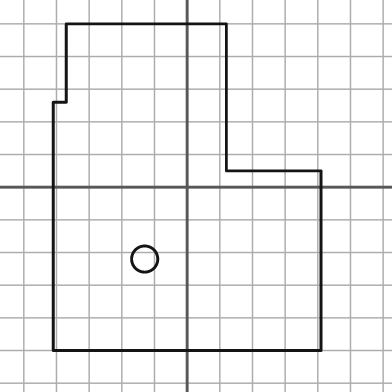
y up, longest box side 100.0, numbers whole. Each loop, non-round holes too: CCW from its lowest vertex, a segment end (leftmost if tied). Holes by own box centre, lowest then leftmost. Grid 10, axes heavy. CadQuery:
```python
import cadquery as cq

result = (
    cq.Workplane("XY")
    .moveTo(-41.0, -50.0)
    .lineTo(41.0, -50.0)
    .lineTo(41.0, 5.0)
    .lineTo(12.0, 5.0)
    .lineTo(12.0, 50.0)
    .lineTo(-37.0, 50.0)
    .lineTo(-37.0, 26.0)
    .lineTo(-41.0, 26.0)
    .close()
    .moveTo(-13.0, -22.0)
    .circle(4.0)
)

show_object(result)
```